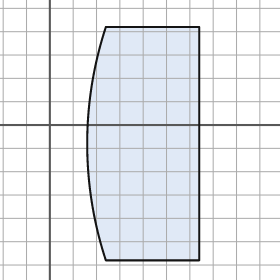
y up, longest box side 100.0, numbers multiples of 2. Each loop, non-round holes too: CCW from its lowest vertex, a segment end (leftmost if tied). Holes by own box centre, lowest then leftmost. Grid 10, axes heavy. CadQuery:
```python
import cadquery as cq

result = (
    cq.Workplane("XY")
    .moveTo(24.0, -58.0)
    .lineTo(64.0, -58.0)
    .lineTo(64.0, 42.0)
    .lineTo(24.0, 42.0)
    .threePointArc((16.0, -8.0), (24.0, -58.0))
    .close()
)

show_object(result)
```